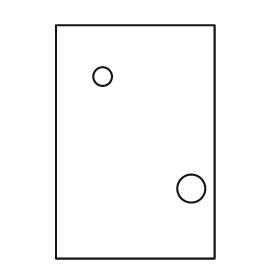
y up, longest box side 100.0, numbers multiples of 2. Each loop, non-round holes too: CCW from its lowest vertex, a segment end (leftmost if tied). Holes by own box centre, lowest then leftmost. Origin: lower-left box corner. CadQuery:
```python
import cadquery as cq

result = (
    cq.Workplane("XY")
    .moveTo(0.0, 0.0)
    .lineTo(68.0, 0.0)
    .lineTo(68.0, 100.0)
    .lineTo(0.0, 100.0)
    .close()
    .moveTo(58.0, 30.0)
    .circle(6.0)
    .moveTo(20.0, 78.0)
    .circle(4.0)
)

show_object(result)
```